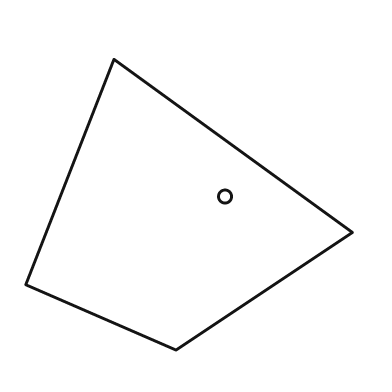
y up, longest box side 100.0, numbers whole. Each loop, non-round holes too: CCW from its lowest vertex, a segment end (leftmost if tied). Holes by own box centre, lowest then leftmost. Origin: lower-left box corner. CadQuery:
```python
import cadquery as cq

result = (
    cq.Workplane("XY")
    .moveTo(46.0, 0.0)
    .lineTo(100.0, 36.0)
    .lineTo(27.0, 89.0)
    .lineTo(0.0, 20.0)
    .close()
    .moveTo(61.0, 47.0)
    .circle(2.0)
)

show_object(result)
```